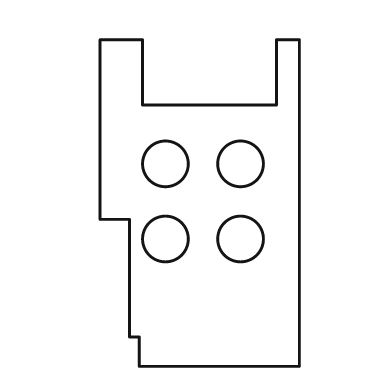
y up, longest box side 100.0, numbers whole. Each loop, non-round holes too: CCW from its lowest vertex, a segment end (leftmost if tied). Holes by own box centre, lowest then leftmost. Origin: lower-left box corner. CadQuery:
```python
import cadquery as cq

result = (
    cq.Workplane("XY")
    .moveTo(12.0, 0.0)
    .lineTo(61.0, 0.0)
    .lineTo(61.0, 100.0)
    .lineTo(54.0, 100.0)
    .lineTo(54.0, 80.0)
    .lineTo(13.0, 80.0)
    .lineTo(13.0, 100.0)
    .lineTo(0.0, 100.0)
    .lineTo(0.0, 45.0)
    .lineTo(9.0, 45.0)
    .lineTo(9.0, 9.0)
    .lineTo(12.0, 9.0)
    .close()
    .moveTo(20.0, 39.0)
    .circle(7.0)
    .moveTo(43.0, 39.0)
    .circle(7.0)
    .moveTo(20.0, 62.0)
    .circle(7.0)
    .moveTo(43.0, 62.0)
    .circle(7.0)
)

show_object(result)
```